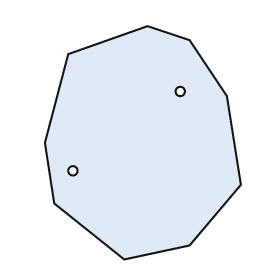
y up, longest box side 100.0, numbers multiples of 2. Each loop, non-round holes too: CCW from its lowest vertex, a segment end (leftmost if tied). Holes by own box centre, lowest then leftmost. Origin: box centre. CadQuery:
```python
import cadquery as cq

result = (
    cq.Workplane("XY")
    .moveTo(-8.0, -50.0)
    .lineTo(20.0, -44.0)
    .lineTo(42.0, -18.0)
    .lineTo(36.0, 20.0)
    .lineTo(20.0, 44.0)
    .lineTo(2.0, 50.0)
    .lineTo(-32.0, 38.0)
    .lineTo(-42.0, 0.0)
    .lineTo(-38.0, -26.0)
    .close()
    .moveTo(-30.0, -12.0)
    .circle(2.0)
    .moveTo(16.0, 22.0)
    .circle(2.0)
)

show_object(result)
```